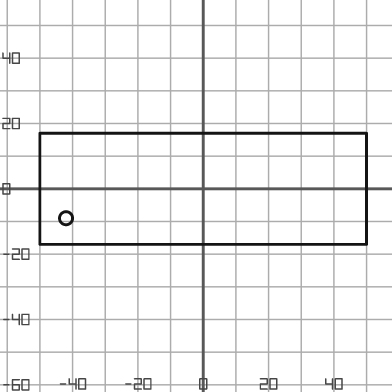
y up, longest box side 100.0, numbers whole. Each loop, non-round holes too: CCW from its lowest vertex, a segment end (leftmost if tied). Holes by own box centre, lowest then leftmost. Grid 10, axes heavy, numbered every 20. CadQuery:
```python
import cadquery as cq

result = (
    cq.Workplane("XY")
    .moveTo(-50.0, -17.0)
    .lineTo(50.0, -17.0)
    .lineTo(50.0, 17.0)
    .lineTo(-50.0, 17.0)
    .close()
    .moveTo(-42.0, -9.0)
    .circle(2.0)
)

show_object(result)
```